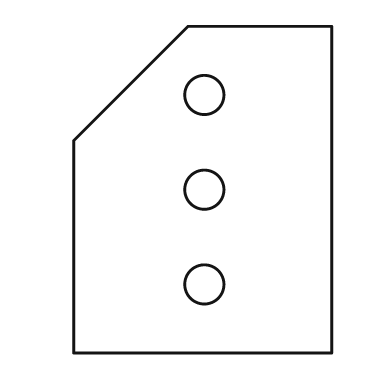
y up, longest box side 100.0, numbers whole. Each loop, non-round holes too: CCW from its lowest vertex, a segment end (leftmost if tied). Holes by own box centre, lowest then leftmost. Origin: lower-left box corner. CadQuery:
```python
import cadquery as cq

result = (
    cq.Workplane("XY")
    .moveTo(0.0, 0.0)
    .lineTo(79.0, 0.0)
    .lineTo(79.0, 100.0)
    .lineTo(35.0, 100.0)
    .lineTo(0.0, 65.0)
    .close()
    .moveTo(40.0, 21.0)
    .circle(6.0)
    .moveTo(40.0, 50.0)
    .circle(6.0)
    .moveTo(40.0, 79.0)
    .circle(6.0)
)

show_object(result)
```